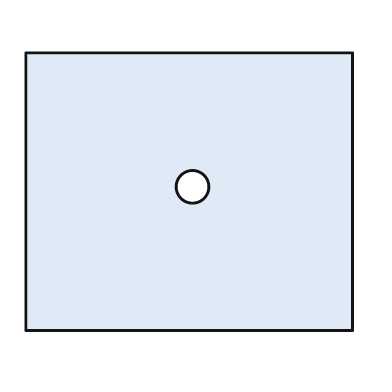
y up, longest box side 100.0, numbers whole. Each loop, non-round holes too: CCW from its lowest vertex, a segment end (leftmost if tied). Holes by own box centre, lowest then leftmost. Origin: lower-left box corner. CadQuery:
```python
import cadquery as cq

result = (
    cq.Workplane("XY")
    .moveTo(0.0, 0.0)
    .lineTo(100.0, 0.0)
    .lineTo(100.0, 85.0)
    .lineTo(0.0, 85.0)
    .close()
    .moveTo(51.0, 44.0)
    .circle(5.0)
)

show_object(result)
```